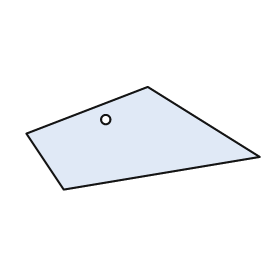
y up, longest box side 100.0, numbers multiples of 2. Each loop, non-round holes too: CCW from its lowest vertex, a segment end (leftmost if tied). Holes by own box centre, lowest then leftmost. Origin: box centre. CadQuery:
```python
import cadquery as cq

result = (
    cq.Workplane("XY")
    .moveTo(-34.0, -22.0)
    .lineTo(50.0, -8.0)
    .lineTo(2.0, 22.0)
    .lineTo(-50.0, 2.0)
    .close()
    .moveTo(-16.0, 8.0)
    .circle(2.0)
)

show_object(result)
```